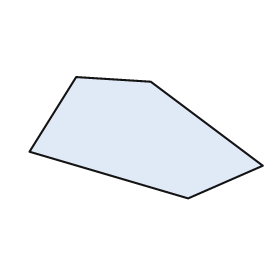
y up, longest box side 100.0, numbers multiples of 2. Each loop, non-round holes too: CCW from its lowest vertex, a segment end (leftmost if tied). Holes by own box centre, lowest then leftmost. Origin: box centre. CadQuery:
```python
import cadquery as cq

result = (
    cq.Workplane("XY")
    .moveTo(18.0, -26.0)
    .lineTo(50.0, -12.0)
    .lineTo(2.0, 24.0)
    .lineTo(-30.0, 26.0)
    .lineTo(-50.0, -6.0)
    .close()
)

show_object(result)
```